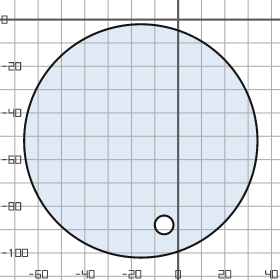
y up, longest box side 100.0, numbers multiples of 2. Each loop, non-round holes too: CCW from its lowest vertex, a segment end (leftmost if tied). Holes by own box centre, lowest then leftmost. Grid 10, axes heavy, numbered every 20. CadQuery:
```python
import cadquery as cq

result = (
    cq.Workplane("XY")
    .moveTo(-16.0, -52.0)
    .circle(50.0)
    .moveTo(-6.0, -88.0)
    .circle(4.0)
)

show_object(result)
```